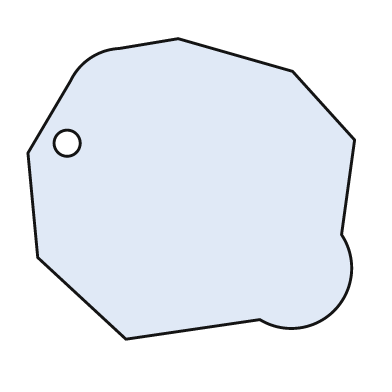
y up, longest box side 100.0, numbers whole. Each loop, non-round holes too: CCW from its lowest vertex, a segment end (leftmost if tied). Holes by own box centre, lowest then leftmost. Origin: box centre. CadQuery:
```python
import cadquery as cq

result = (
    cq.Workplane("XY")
    .moveTo(-20.0, -46.0)
    .lineTo(21.0, -40.0)
    .threePointArc((44.0, -37.0), (46.0, -14.0))
    .lineTo(50.0, 15.0)
    .lineTo(31.0, 36.0)
    .lineTo(-4.0, 46.0)
    .lineTo(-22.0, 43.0)
    .threePointArc((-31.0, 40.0), (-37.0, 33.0))
    .lineTo(-50.0, 11.0)
    .lineTo(-47.0, -21.0)
    .close()
    .moveTo(-38.0, 14.0)
    .circle(4.0)
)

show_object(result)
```